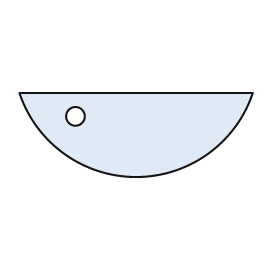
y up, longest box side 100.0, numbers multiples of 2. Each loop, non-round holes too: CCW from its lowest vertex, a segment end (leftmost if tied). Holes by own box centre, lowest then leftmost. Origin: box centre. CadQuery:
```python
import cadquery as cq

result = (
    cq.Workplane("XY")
    .moveTo(-50.0, 18.0)
    .threePointArc((0.0, -18.0), (50.0, 18.0))
    .close()
    .moveTo(-26.0, 8.0)
    .circle(4.0)
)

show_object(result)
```